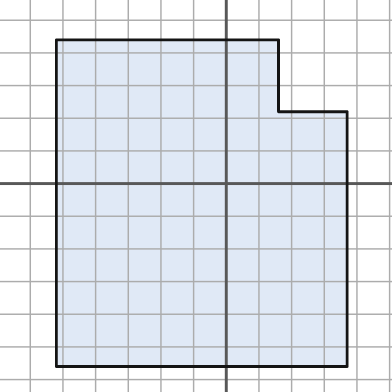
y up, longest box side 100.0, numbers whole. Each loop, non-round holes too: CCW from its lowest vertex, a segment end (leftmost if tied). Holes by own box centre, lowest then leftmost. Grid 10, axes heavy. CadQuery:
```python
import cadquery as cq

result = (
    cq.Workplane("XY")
    .moveTo(-52.0, -56.0)
    .lineTo(37.0, -56.0)
    .lineTo(37.0, 22.0)
    .lineTo(16.0, 22.0)
    .lineTo(16.0, 44.0)
    .lineTo(-52.0, 44.0)
    .close()
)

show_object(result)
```